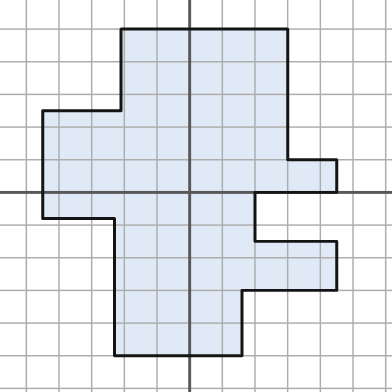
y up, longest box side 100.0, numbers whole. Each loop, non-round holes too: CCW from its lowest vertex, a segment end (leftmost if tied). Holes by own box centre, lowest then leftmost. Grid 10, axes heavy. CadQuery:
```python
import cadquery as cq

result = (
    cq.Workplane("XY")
    .moveTo(-23.0, -50.0)
    .lineTo(16.0, -50.0)
    .lineTo(16.0, -30.0)
    .lineTo(45.0, -30.0)
    .lineTo(45.0, -15.0)
    .lineTo(20.0, -15.0)
    .lineTo(20.0, 0.0)
    .lineTo(45.0, 0.0)
    .lineTo(45.0, 10.0)
    .lineTo(30.0, 10.0)
    .lineTo(30.0, 50.0)
    .lineTo(-21.0, 50.0)
    .lineTo(-21.0, 25.0)
    .lineTo(-45.0, 25.0)
    .lineTo(-45.0, -8.0)
    .lineTo(-23.0, -8.0)
    .close()
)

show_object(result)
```